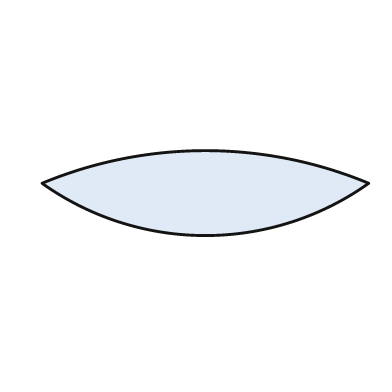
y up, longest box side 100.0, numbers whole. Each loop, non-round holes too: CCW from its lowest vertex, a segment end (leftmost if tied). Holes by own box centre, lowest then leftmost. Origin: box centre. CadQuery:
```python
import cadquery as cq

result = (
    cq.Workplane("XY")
    .moveTo(-50.0, 3.0)
    .threePointArc((0.0, -13.0), (50.0, 3.0))
    .threePointArc((0.0, 13.0), (-50.0, 3.0))
    .close()
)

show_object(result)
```